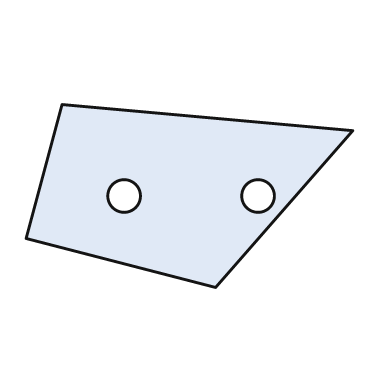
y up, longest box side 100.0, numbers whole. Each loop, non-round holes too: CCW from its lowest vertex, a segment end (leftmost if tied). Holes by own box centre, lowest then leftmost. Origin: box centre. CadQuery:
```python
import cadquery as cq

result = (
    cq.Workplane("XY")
    .moveTo(8.0, -28.0)
    .lineTo(50.0, 20.0)
    .lineTo(-39.0, 28.0)
    .lineTo(-50.0, -13.0)
    .close()
    .moveTo(-20.0, 0.0)
    .circle(5.0)
    .moveTo(21.0, 0.0)
    .circle(5.0)
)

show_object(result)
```